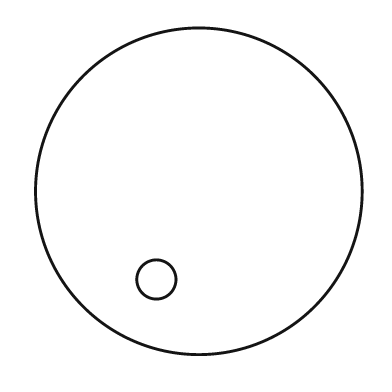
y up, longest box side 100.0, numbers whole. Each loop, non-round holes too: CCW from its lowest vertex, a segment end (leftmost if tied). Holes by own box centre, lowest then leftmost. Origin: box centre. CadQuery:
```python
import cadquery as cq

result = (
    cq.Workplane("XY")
    .moveTo(0.0, 0.0)
    .circle(50.0)
    .moveTo(-13.0, -27.0)
    .circle(6.0)
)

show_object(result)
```